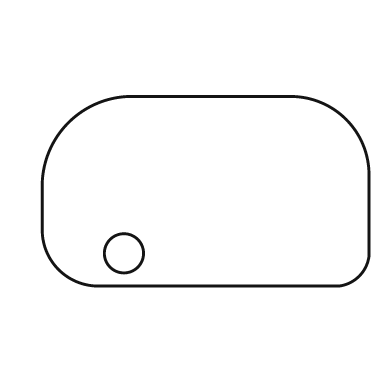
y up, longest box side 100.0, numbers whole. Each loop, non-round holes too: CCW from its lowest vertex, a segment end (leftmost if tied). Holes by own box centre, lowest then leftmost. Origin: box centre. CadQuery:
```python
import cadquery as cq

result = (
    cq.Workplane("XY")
    .moveTo(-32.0, -29.0)
    .lineTo(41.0, -29.0)
    .threePointArc((47.0, -26.0), (50.0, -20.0))
    .lineTo(50.0, 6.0)
    .threePointArc((43.0, 22.0), (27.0, 29.0))
    .lineTo(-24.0, 29.0)
    .threePointArc((-42.0, 21.0), (-50.0, 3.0))
    .lineTo(-50.0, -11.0)
    .threePointArc((-45.0, -24.0), (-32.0, -29.0))
    .close()
    .moveTo(-25.0, -19.0)
    .circle(6.0)
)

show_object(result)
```